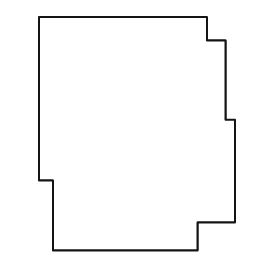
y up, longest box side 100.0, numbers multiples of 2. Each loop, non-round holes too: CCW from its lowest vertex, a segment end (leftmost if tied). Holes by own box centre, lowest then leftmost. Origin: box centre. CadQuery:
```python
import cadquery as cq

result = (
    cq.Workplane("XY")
    .moveTo(-36.0, -50.0)
    .lineTo(26.0, -50.0)
    .lineTo(26.0, -38.0)
    .lineTo(42.0, -38.0)
    .lineTo(42.0, 6.0)
    .lineTo(38.0, 6.0)
    .lineTo(38.0, 40.0)
    .lineTo(30.0, 40.0)
    .lineTo(30.0, 50.0)
    .lineTo(-42.0, 50.0)
    .lineTo(-42.0, -20.0)
    .lineTo(-36.0, -20.0)
    .close()
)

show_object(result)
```